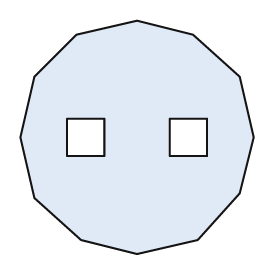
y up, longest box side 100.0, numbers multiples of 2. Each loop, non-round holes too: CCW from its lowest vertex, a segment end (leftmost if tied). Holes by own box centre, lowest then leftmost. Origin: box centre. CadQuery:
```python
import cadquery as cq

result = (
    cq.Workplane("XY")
    .moveTo(0.0, -50.0)
    .lineTo(26.0, -44.0)
    .lineTo(44.0, -24.0)
    .lineTo(50.0, 0.0)
    .lineTo(44.0, 26.0)
    .lineTo(24.0, 44.0)
    .lineTo(0.0, 50.0)
    .lineTo(-26.0, 44.0)
    .lineTo(-44.0, 26.0)
    .lineTo(-50.0, 0.0)
    .lineTo(-44.0, -26.0)
    .lineTo(-24.0, -44.0)
    .close()
    .moveTo(-30.0, -8.0)
    .lineTo(-14.0, -8.0)
    .lineTo(-14.0, 8.0)
    .lineTo(-30.0, 8.0)
    .close()
    .moveTo(14.0, -8.0)
    .lineTo(30.0, -8.0)
    .lineTo(30.0, 8.0)
    .lineTo(14.0, 8.0)
    .close()
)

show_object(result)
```